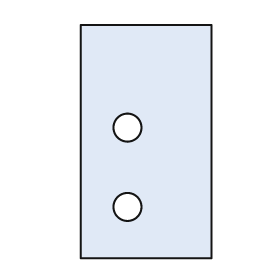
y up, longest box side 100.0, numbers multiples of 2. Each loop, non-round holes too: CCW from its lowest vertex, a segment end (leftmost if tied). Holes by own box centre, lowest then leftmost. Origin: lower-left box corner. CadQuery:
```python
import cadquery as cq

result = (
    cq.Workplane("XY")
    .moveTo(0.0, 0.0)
    .lineTo(56.0, 0.0)
    .lineTo(56.0, 100.0)
    .lineTo(0.0, 100.0)
    .close()
    .moveTo(20.0, 22.0)
    .circle(6.0)
    .moveTo(20.0, 56.0)
    .circle(6.0)
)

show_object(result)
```